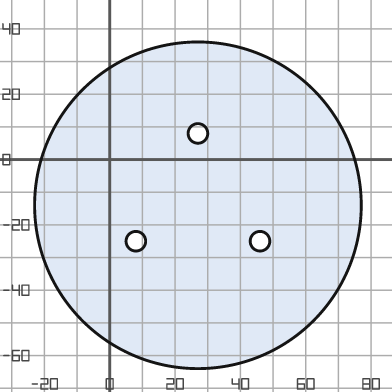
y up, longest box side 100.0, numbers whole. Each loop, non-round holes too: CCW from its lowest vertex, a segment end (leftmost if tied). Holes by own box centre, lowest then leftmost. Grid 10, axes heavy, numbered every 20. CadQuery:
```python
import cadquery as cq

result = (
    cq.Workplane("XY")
    .moveTo(27.0, -14.0)
    .circle(50.0)
    .moveTo(8.0, -25.0)
    .circle(3.0)
    .moveTo(46.0, -25.0)
    .circle(3.0)
    .moveTo(27.0, 8.0)
    .circle(3.0)
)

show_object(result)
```